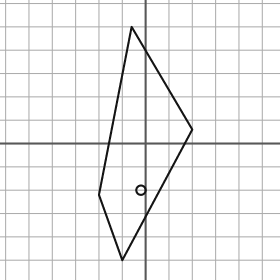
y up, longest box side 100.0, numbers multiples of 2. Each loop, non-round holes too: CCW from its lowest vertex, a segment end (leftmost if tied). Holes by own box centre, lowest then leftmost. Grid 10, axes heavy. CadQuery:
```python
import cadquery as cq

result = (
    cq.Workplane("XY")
    .moveTo(-10.0, -50.0)
    .lineTo(20.0, 6.0)
    .lineTo(-6.0, 50.0)
    .lineTo(-20.0, -22.0)
    .close()
    .moveTo(-2.0, -20.0)
    .circle(2.0)
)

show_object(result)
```